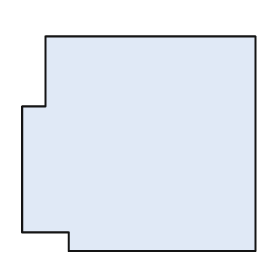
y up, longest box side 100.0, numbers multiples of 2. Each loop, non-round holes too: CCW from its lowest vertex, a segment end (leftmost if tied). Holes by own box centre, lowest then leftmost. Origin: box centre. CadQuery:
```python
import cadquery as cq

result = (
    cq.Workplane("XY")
    .moveTo(-30.0, -46.0)
    .lineTo(50.0, -46.0)
    .lineTo(50.0, 46.0)
    .lineTo(-40.0, 46.0)
    .lineTo(-40.0, 16.0)
    .lineTo(-50.0, 16.0)
    .lineTo(-50.0, -38.0)
    .lineTo(-30.0, -38.0)
    .close()
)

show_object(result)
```